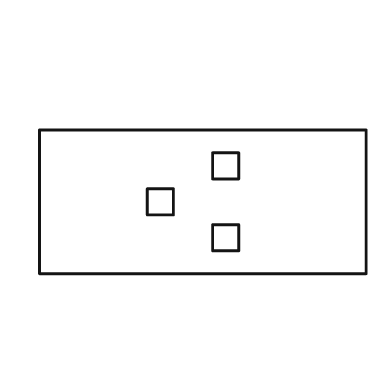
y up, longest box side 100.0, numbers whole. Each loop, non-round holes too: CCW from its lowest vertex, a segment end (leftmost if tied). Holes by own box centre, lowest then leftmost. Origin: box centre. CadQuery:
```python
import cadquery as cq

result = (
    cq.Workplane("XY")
    .moveTo(-50.0, -22.0)
    .lineTo(50.0, -22.0)
    .lineTo(50.0, 22.0)
    .lineTo(-50.0, 22.0)
    .close()
    .moveTo(3.0, -15.0)
    .lineTo(11.0, -15.0)
    .lineTo(11.0, -7.0)
    .lineTo(3.0, -7.0)
    .close()
    .moveTo(-17.0, -4.0)
    .lineTo(-9.0, -4.0)
    .lineTo(-9.0, 4.0)
    .lineTo(-17.0, 4.0)
    .close()
    .moveTo(3.0, 7.0)
    .lineTo(11.0, 7.0)
    .lineTo(11.0, 15.0)
    .lineTo(3.0, 15.0)
    .close()
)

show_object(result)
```